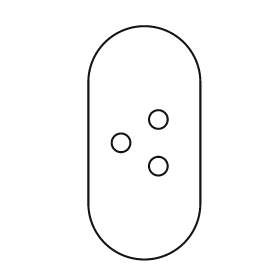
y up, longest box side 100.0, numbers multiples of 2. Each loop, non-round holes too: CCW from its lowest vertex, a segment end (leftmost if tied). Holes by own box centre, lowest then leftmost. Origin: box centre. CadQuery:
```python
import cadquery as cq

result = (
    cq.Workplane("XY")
    .moveTo(-24.0, -26.0)
    .threePointArc((0.0, -50.0), (24.0, -26.0))
    .lineTo(24.0, 26.0)
    .threePointArc((0.0, 50.0), (-24.0, 26.0))
    .close()
    .moveTo(6.0, -10.0)
    .circle(4.0)
    .moveTo(-10.0, 0.0)
    .circle(4.0)
    .moveTo(6.0, 10.0)
    .circle(4.0)
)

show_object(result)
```